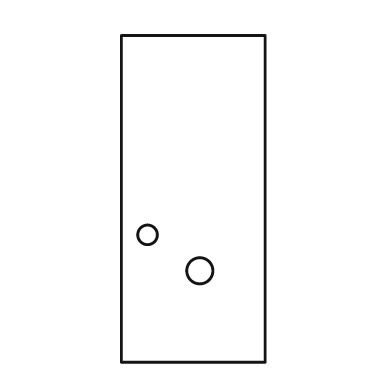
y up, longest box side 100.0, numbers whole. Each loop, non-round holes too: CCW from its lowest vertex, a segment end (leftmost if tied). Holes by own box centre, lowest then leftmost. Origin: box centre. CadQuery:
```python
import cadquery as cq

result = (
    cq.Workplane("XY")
    .moveTo(-22.0, -50.0)
    .lineTo(22.0, -50.0)
    .lineTo(22.0, 50.0)
    .lineTo(-22.0, 50.0)
    .close()
    .moveTo(2.0, -22.0)
    .circle(4.0)
    .moveTo(-14.0, -11.0)
    .circle(3.0)
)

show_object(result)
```